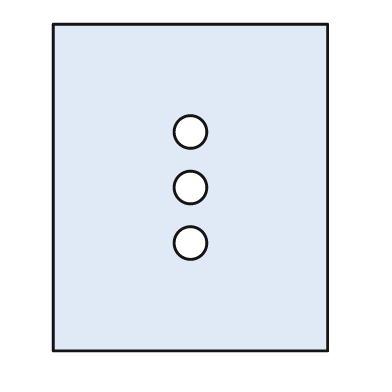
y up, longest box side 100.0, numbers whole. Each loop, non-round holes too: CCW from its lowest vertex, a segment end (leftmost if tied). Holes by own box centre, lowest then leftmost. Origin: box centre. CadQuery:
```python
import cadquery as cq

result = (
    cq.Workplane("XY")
    .moveTo(-42.0, -50.0)
    .lineTo(42.0, -50.0)
    .lineTo(42.0, 50.0)
    .lineTo(-42.0, 50.0)
    .close()
    .moveTo(0.0, -17.0)
    .circle(5.0)
    .moveTo(0.0, 0.0)
    .circle(5.0)
    .moveTo(0.0, 17.0)
    .circle(5.0)
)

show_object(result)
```